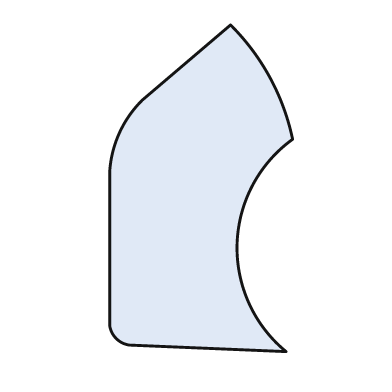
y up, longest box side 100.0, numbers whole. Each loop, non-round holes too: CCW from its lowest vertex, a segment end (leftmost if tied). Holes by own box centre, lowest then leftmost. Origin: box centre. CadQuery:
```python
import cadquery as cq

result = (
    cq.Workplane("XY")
    .moveTo(26.0, -50.0)
    .threePointArc((11.0, -17.0), (28.0, 15.0))
    .threePointArc((21.0, 34.0), (9.0, 50.0))
    .lineTo(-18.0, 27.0)
    .threePointArc((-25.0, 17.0), (-28.0, 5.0))
    .lineTo(-28.0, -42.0)
    .threePointArc((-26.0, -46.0), (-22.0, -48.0))
    .close()
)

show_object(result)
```